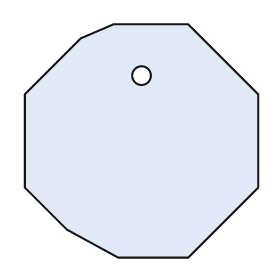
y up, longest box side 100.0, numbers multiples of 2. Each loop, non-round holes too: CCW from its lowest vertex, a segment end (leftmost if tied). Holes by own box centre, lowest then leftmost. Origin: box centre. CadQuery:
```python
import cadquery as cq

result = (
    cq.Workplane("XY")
    .moveTo(-10.0, -50.0)
    .lineTo(20.0, -50.0)
    .lineTo(50.0, -20.0)
    .lineTo(50.0, 20.0)
    .lineTo(20.0, 50.0)
    .lineTo(-12.0, 50.0)
    .lineTo(-26.0, 44.0)
    .lineTo(-50.0, 20.0)
    .lineTo(-50.0, -20.0)
    .lineTo(-32.0, -38.0)
    .close()
    .moveTo(0.0, 28.0)
    .circle(4.0)
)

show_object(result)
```